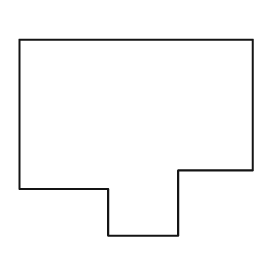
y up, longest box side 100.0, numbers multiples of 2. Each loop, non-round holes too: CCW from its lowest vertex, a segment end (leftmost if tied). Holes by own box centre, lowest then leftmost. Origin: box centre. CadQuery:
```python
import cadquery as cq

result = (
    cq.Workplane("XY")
    .moveTo(-12.0, -42.0)
    .lineTo(18.0, -42.0)
    .lineTo(18.0, -14.0)
    .lineTo(50.0, -14.0)
    .lineTo(50.0, 42.0)
    .lineTo(-50.0, 42.0)
    .lineTo(-50.0, -22.0)
    .lineTo(-12.0, -22.0)
    .close()
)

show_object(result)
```